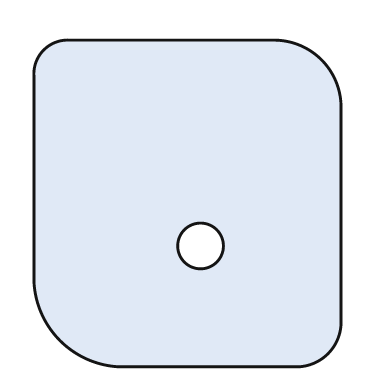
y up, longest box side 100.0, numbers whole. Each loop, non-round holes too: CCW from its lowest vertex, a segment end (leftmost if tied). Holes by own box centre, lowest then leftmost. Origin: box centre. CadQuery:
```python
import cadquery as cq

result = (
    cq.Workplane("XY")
    .moveTo(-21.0, -50.0)
    .lineTo(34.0, -50.0)
    .threePointArc((43.0, -46.0), (47.0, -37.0))
    .lineTo(47.0, 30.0)
    .threePointArc((41.0, 44.0), (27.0, 50.0))
    .lineTo(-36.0, 50.0)
    .threePointArc((-44.0, 47.0), (-47.0, 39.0))
    .lineTo(-47.0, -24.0)
    .threePointArc((-39.0, -42.0), (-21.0, -50.0))
    .close()
    .moveTo(4.0, -13.0)
    .circle(7.0)
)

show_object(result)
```